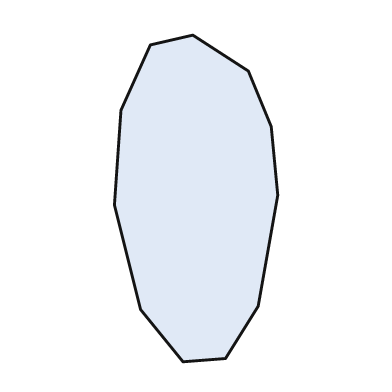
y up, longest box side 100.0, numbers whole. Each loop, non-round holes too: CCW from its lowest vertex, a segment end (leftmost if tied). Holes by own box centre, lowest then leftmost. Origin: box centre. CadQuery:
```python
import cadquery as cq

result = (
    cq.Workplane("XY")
    .moveTo(-4.0, -50.0)
    .lineTo(9.0, -49.0)
    .lineTo(19.0, -33.0)
    .lineTo(25.0, 1.0)
    .lineTo(23.0, 22.0)
    .lineTo(16.0, 39.0)
    .lineTo(-1.0, 50.0)
    .lineTo(-14.0, 47.0)
    .lineTo(-23.0, 27.0)
    .lineTo(-25.0, -2.0)
    .lineTo(-17.0, -34.0)
    .close()
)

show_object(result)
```